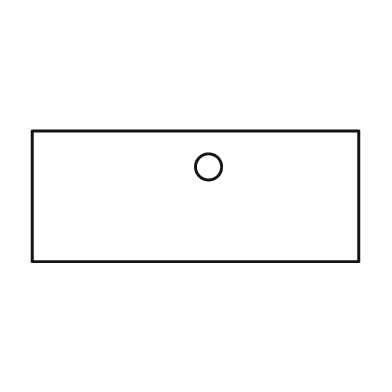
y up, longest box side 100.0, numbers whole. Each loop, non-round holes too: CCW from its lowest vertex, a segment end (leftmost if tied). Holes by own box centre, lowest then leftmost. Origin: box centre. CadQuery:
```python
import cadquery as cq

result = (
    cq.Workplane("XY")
    .moveTo(-50.0, -20.0)
    .lineTo(50.0, -20.0)
    .lineTo(50.0, 20.0)
    .lineTo(-50.0, 20.0)
    .close()
    .moveTo(4.0, 9.0)
    .circle(4.0)
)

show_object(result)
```